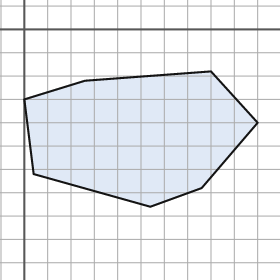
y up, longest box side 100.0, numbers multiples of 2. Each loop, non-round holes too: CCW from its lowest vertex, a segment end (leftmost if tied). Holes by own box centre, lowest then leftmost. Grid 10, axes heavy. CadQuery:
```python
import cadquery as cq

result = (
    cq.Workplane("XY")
    .moveTo(54.0, -76.0)
    .lineTo(76.0, -68.0)
    .lineTo(100.0, -40.0)
    .lineTo(80.0, -18.0)
    .lineTo(26.0, -22.0)
    .lineTo(0.0, -30.0)
    .lineTo(4.0, -62.0)
    .close()
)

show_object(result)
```